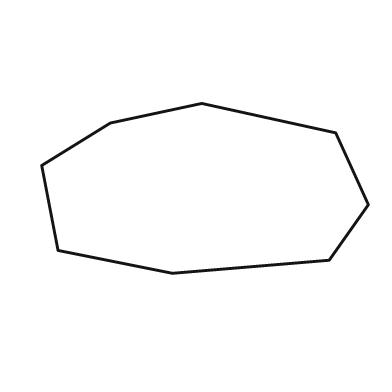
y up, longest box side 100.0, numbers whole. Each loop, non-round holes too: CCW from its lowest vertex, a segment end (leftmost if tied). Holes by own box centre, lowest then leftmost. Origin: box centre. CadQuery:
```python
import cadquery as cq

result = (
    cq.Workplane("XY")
    .moveTo(-10.0, -26.0)
    .lineTo(38.0, -22.0)
    .lineTo(50.0, -5.0)
    .lineTo(40.0, 17.0)
    .lineTo(-1.0, 26.0)
    .lineTo(-29.0, 20.0)
    .lineTo(-50.0, 7.0)
    .lineTo(-45.0, -19.0)
    .close()
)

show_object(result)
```